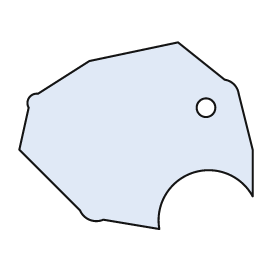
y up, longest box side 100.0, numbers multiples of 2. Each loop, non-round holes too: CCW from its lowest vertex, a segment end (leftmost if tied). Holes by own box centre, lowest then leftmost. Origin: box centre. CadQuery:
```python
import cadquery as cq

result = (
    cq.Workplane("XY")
    .moveTo(10.0, -40.0)
    .threePointArc((24.0, -16.0), (50.0, -26.0))
    .lineTo(50.0, -6.0)
    .lineTo(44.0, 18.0)
    .threePointArc((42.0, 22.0), (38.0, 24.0))
    .lineTo(18.0, 40.0)
    .lineTo(-20.0, 32.0)
    .lineTo(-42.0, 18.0)
    .threePointArc((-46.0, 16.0), (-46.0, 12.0))
    .lineTo(-50.0, -6.0)
    .lineTo(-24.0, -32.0)
    .threePointArc((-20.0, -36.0), (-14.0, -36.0))
    .close()
    .moveTo(30.0, 12.0)
    .circle(4.0)
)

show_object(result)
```